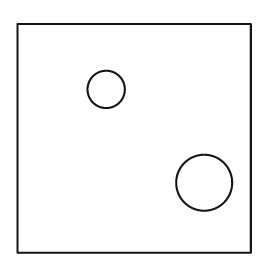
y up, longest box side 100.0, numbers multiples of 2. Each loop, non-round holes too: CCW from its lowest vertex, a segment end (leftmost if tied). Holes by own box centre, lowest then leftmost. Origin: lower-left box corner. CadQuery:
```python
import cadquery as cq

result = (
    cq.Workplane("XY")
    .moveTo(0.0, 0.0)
    .lineTo(100.0, 0.0)
    .lineTo(100.0, 98.0)
    .lineTo(0.0, 98.0)
    .close()
    .moveTo(80.0, 30.0)
    .circle(12.0)
    .moveTo(38.0, 70.0)
    .circle(8.0)
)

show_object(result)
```